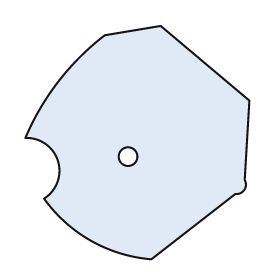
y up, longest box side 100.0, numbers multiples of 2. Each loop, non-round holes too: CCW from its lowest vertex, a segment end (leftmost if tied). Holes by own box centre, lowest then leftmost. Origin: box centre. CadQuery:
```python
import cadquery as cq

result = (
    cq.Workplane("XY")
    .moveTo(6.0, -50.0)
    .lineTo(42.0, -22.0)
    .threePointArc((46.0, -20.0), (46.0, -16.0))
    .lineTo(48.0, 18.0)
    .lineTo(10.0, 50.0)
    .lineTo(-14.0, 46.0)
    .threePointArc((-34.0, 26.0), (-48.0, 2.0))
    .threePointArc((-34.0, -8.0), (-40.0, -24.0))
    .threePointArc((-20.0, -42.0), (6.0, -50.0))
    .close()
    .moveTo(-4.0, -6.0)
    .circle(4.0)
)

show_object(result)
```